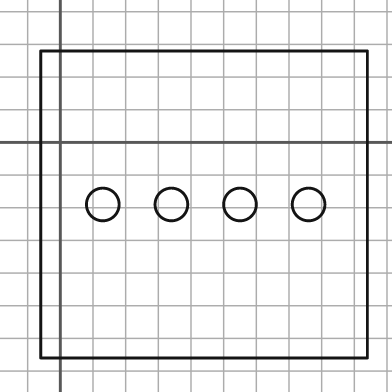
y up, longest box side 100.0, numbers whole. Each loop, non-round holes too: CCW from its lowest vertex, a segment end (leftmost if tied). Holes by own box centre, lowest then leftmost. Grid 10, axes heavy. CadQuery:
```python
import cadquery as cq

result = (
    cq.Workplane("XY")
    .moveTo(-6.0, -66.0)
    .lineTo(94.0, -66.0)
    .lineTo(94.0, 28.0)
    .lineTo(-6.0, 28.0)
    .close()
    .moveTo(13.0, -19.0)
    .circle(5.0)
    .moveTo(34.0, -19.0)
    .circle(5.0)
    .moveTo(55.0, -19.0)
    .circle(5.0)
    .moveTo(76.0, -19.0)
    .circle(5.0)
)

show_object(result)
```